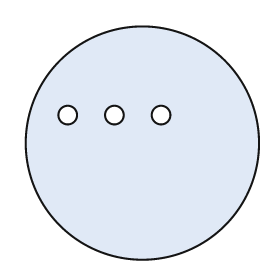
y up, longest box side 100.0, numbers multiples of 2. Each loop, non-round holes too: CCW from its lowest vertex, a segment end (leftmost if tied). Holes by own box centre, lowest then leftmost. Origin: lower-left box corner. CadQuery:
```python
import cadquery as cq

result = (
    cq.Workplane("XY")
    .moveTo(50.0, 50.0)
    .circle(50.0)
    .moveTo(18.0, 62.0)
    .circle(4.0)
    .moveTo(38.0, 62.0)
    .circle(4.0)
    .moveTo(58.0, 62.0)
    .circle(4.0)
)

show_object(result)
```